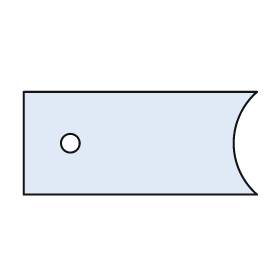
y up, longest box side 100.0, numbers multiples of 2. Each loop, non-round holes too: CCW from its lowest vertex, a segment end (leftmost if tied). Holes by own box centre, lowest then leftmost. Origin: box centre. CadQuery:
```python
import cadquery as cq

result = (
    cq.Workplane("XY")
    .moveTo(-50.0, -22.0)
    .lineTo(50.0, -22.0)
    .threePointArc((40.0, 0.0), (50.0, 22.0))
    .lineTo(-50.0, 22.0)
    .close()
    .moveTo(-30.0, 0.0)
    .circle(4.0)
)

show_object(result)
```